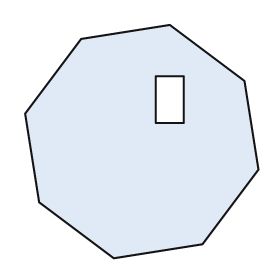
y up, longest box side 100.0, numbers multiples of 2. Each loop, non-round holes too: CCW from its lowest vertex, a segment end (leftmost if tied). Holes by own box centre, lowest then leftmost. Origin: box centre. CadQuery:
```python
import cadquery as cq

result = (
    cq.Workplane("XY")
    .moveTo(-12.0, -50.0)
    .lineTo(26.0, -44.0)
    .lineTo(50.0, -12.0)
    .lineTo(44.0, 26.0)
    .lineTo(12.0, 50.0)
    .lineTo(-26.0, 44.0)
    .lineTo(-50.0, 12.0)
    .lineTo(-44.0, -26.0)
    .close()
    .moveTo(6.0, 8.0)
    .lineTo(18.0, 8.0)
    .lineTo(18.0, 28.0)
    .lineTo(6.0, 28.0)
    .close()
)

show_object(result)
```